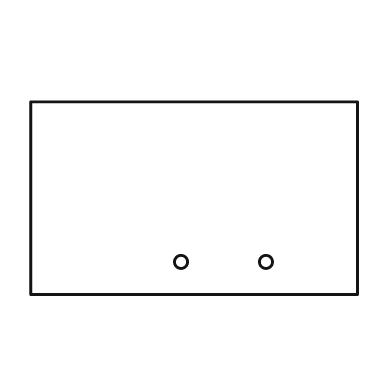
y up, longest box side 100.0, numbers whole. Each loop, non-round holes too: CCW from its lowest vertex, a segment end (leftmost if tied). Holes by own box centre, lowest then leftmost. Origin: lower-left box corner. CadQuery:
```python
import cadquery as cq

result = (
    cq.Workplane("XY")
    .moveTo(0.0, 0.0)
    .lineTo(100.0, 0.0)
    .lineTo(100.0, 59.0)
    .lineTo(0.0, 59.0)
    .close()
    .moveTo(46.0, 10.0)
    .circle(2.0)
    .moveTo(72.0, 10.0)
    .circle(2.0)
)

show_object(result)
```